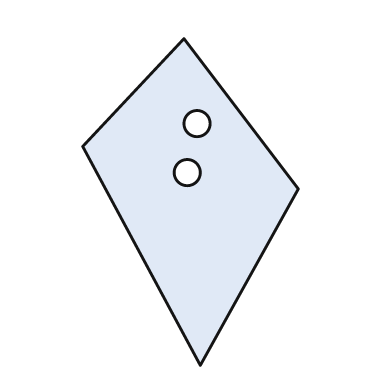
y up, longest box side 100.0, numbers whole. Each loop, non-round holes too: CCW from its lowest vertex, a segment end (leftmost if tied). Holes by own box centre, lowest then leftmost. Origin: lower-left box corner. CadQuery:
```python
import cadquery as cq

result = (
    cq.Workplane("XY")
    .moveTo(36.0, 0.0)
    .lineTo(66.0, 54.0)
    .lineTo(31.0, 100.0)
    .lineTo(0.0, 67.0)
    .close()
    .moveTo(32.0, 59.0)
    .circle(4.0)
    .moveTo(35.0, 74.0)
    .circle(4.0)
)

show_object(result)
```